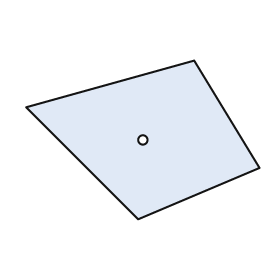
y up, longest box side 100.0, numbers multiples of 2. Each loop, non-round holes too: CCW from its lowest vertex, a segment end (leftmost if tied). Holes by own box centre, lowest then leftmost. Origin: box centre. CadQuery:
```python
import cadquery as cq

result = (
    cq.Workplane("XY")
    .moveTo(-2.0, -34.0)
    .lineTo(50.0, -12.0)
    .lineTo(22.0, 34.0)
    .lineTo(-50.0, 14.0)
    .close()
    .moveTo(0.0, 0.0)
    .circle(2.0)
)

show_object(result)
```